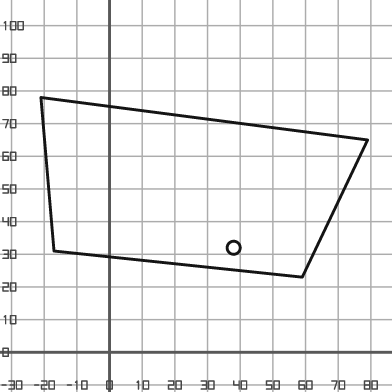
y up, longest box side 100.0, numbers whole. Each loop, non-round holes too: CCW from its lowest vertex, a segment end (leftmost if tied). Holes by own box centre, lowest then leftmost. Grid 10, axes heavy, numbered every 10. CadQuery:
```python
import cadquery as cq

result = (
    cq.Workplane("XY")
    .moveTo(59.0, 23.0)
    .lineTo(79.0, 65.0)
    .lineTo(-21.0, 78.0)
    .lineTo(-17.0, 31.0)
    .close()
    .moveTo(38.0, 32.0)
    .circle(2.0)
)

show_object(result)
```